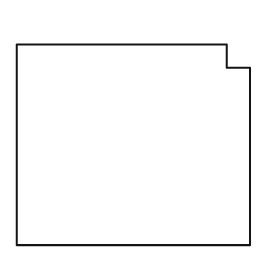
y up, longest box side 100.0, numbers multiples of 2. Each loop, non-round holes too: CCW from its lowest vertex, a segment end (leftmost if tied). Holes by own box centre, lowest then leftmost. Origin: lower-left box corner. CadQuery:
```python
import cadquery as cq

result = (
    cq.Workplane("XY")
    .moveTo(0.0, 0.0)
    .lineTo(100.0, 0.0)
    .lineTo(100.0, 76.0)
    .lineTo(90.0, 76.0)
    .lineTo(90.0, 86.0)
    .lineTo(0.0, 86.0)
    .close()
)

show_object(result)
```